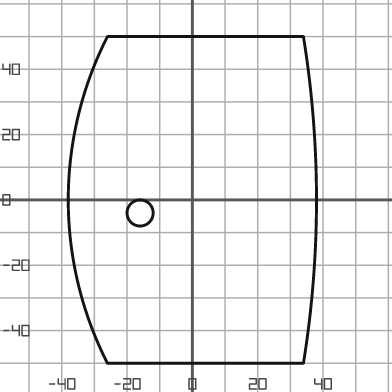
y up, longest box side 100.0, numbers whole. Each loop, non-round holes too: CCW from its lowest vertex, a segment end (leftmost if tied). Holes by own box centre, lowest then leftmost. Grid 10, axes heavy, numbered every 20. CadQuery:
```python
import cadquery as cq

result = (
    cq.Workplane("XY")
    .moveTo(-26.0, -50.0)
    .lineTo(34.0, -50.0)
    .threePointArc((38.0, 0.0), (34.0, 50.0))
    .lineTo(-26.0, 50.0)
    .threePointArc((-38.0, 0.0), (-26.0, -50.0))
    .close()
    .moveTo(-16.0, -4.0)
    .circle(4.0)
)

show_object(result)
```